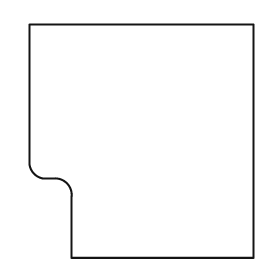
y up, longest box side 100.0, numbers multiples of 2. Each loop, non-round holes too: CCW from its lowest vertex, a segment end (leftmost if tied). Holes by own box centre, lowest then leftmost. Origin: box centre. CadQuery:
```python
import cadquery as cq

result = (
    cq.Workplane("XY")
    .moveTo(-30.0, -50.0)
    .lineTo(48.0, -50.0)
    .lineTo(48.0, 50.0)
    .lineTo(-48.0, 50.0)
    .lineTo(-48.0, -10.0)
    .threePointArc((-46.0, -14.0), (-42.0, -16.0))
    .lineTo(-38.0, -16.0)
    .threePointArc((-32.0, -18.0), (-30.0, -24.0))
    .close()
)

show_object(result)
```